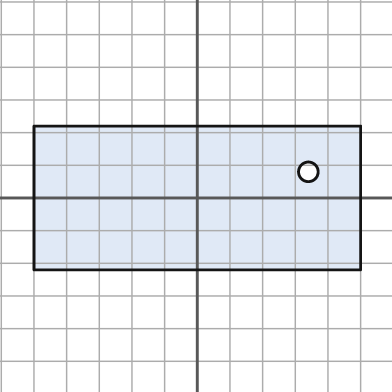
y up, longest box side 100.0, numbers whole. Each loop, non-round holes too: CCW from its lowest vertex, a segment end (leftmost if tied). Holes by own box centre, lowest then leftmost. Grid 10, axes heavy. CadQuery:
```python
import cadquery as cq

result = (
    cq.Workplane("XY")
    .moveTo(-50.0, -22.0)
    .lineTo(50.0, -22.0)
    .lineTo(50.0, 22.0)
    .lineTo(-50.0, 22.0)
    .close()
    .moveTo(34.0, 8.0)
    .circle(3.0)
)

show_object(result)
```